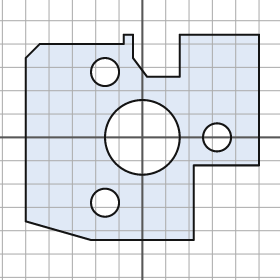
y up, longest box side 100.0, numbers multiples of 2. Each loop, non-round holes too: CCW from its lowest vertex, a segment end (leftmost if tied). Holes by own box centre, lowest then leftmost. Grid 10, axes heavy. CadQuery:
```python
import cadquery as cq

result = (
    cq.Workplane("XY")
    .moveTo(-22.0, -44.0)
    .lineTo(22.0, -44.0)
    .lineTo(22.0, -12.0)
    .lineTo(50.0, -12.0)
    .lineTo(50.0, 44.0)
    .lineTo(16.0, 44.0)
    .lineTo(16.0, 26.0)
    .lineTo(2.0, 26.0)
    .lineTo(-4.0, 34.0)
    .lineTo(-4.0, 44.0)
    .lineTo(-8.0, 44.0)
    .lineTo(-8.0, 40.0)
    .lineTo(-44.0, 40.0)
    .lineTo(-50.0, 34.0)
    .lineTo(-50.0, -36.0)
    .close()
    .moveTo(-16.0, -28.0)
    .circle(6.0)
    .moveTo(0.0, 0.0)
    .circle(16.0)
    .moveTo(32.0, 0.0)
    .circle(6.0)
    .moveTo(-16.0, 28.0)
    .circle(6.0)
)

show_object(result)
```